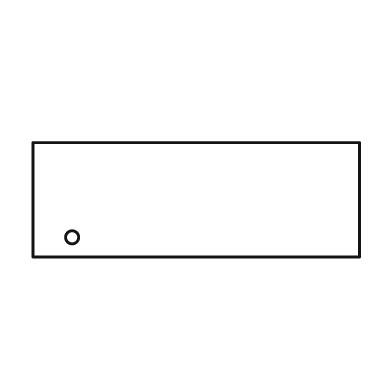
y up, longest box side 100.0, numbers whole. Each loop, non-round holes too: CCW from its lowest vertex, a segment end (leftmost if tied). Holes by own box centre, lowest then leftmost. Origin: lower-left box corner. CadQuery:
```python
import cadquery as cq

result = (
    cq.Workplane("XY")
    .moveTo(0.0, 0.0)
    .lineTo(100.0, 0.0)
    .lineTo(100.0, 35.0)
    .lineTo(0.0, 35.0)
    .close()
    .moveTo(12.0, 6.0)
    .circle(2.0)
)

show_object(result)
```